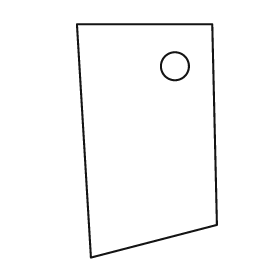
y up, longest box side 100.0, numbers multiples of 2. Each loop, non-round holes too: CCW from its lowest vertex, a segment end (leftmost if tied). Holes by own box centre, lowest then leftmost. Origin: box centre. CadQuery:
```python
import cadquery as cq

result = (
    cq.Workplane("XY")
    .moveTo(-24.0, -50.0)
    .lineTo(30.0, -36.0)
    .lineTo(28.0, 50.0)
    .lineTo(-30.0, 50.0)
    .close()
    .moveTo(12.0, 32.0)
    .circle(6.0)
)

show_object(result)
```